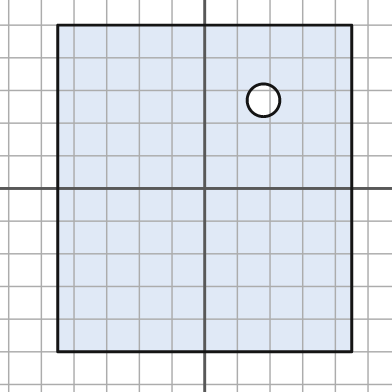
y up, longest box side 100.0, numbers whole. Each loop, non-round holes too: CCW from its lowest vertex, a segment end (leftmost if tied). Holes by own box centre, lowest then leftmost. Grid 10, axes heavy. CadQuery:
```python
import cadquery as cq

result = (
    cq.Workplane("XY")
    .moveTo(-45.0, -50.0)
    .lineTo(45.0, -50.0)
    .lineTo(45.0, 50.0)
    .lineTo(-45.0, 50.0)
    .close()
    .moveTo(18.0, 27.0)
    .circle(5.0)
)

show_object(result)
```